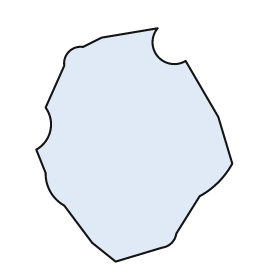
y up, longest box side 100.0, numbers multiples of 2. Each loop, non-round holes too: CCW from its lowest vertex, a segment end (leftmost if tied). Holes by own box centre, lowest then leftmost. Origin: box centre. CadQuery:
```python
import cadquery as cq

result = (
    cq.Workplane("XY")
    .moveTo(-8.0, -50.0)
    .lineTo(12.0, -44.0)
    .threePointArc((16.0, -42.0), (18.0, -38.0))
    .lineTo(28.0, -22.0)
    .threePointArc((36.0, -16.0), (42.0, -8.0))
    .lineTo(36.0, 12.0)
    .lineTo(22.0, 36.0)
    .threePointArc((10.0, 38.0), (10.0, 50.0))
    .lineTo(-14.0, 46.0)
    .lineTo(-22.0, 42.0)
    .threePointArc((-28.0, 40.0), (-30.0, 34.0))
    .lineTo(-38.0, 16.0)
    .threePointArc((-36.0, 6.0), (-42.0, -2.0))
    .lineTo(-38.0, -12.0)
    .threePointArc((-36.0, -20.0), (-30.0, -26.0))
    .lineTo(-18.0, -42.0)
    .close()
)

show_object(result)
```